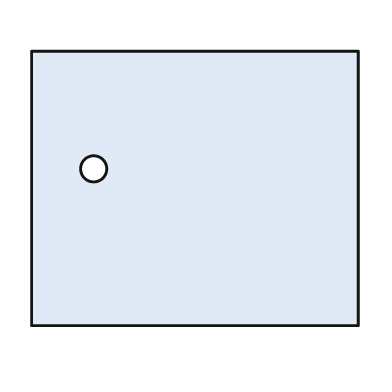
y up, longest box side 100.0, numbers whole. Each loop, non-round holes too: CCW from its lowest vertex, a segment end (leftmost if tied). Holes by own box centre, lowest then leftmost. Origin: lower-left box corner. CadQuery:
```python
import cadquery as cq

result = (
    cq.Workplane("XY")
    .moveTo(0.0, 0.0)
    .lineTo(100.0, 0.0)
    .lineTo(100.0, 84.0)
    .lineTo(0.0, 84.0)
    .close()
    .moveTo(19.0, 48.0)
    .circle(4.0)
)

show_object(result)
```